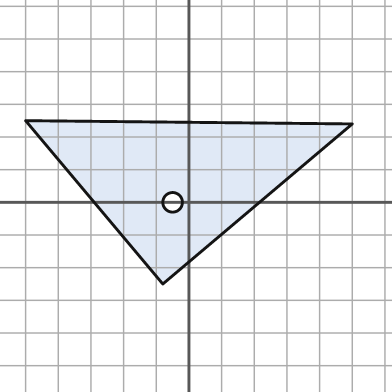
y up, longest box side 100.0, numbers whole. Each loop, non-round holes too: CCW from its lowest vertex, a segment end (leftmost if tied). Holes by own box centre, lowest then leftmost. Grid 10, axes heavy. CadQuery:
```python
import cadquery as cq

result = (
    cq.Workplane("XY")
    .moveTo(-8.0, -25.0)
    .lineTo(50.0, 24.0)
    .lineTo(-50.0, 25.0)
    .close()
    .moveTo(-5.0, 0.0)
    .circle(3.0)
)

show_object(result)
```